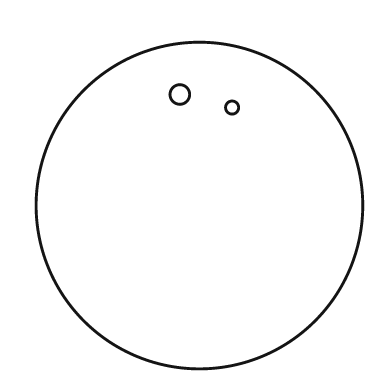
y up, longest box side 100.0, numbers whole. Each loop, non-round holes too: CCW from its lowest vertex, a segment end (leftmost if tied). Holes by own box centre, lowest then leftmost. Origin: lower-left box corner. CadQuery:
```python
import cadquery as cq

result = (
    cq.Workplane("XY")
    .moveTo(50.0, 50.0)
    .circle(50.0)
    .moveTo(60.0, 80.0)
    .circle(2.0)
    .moveTo(44.0, 84.0)
    .circle(3.0)
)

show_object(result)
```